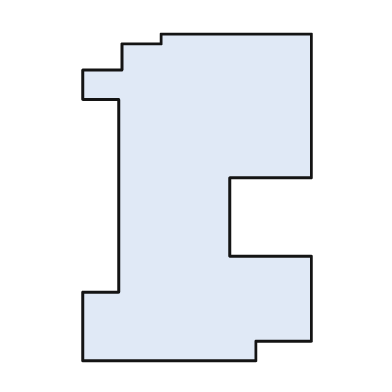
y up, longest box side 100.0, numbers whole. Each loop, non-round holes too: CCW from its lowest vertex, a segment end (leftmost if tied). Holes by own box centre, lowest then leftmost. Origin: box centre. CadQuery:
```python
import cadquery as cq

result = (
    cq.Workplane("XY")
    .moveTo(-35.0, -50.0)
    .lineTo(18.0, -50.0)
    .lineTo(18.0, -44.0)
    .lineTo(35.0, -44.0)
    .lineTo(35.0, -18.0)
    .lineTo(10.0, -18.0)
    .lineTo(10.0, 6.0)
    .lineTo(35.0, 6.0)
    .lineTo(35.0, 50.0)
    .lineTo(-11.0, 50.0)
    .lineTo(-11.0, 47.0)
    .lineTo(-23.0, 47.0)
    .lineTo(-23.0, 39.0)
    .lineTo(-35.0, 39.0)
    .lineTo(-35.0, 30.0)
    .lineTo(-24.0, 30.0)
    .lineTo(-24.0, -29.0)
    .lineTo(-35.0, -29.0)
    .close()
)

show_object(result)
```